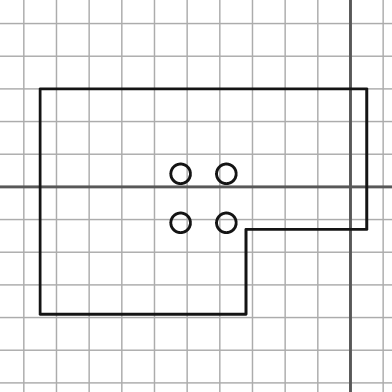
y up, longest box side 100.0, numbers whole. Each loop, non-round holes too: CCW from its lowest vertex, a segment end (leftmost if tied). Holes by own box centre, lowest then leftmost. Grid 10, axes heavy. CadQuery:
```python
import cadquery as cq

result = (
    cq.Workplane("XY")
    .moveTo(-95.0, -39.0)
    .lineTo(-32.0, -39.0)
    .lineTo(-32.0, -13.0)
    .lineTo(5.0, -13.0)
    .lineTo(5.0, 30.0)
    .lineTo(-95.0, 30.0)
    .close()
    .moveTo(-52.0, -11.0)
    .circle(3.0)
    .moveTo(-38.0, -11.0)
    .circle(3.0)
    .moveTo(-52.0, 4.0)
    .circle(3.0)
    .moveTo(-38.0, 4.0)
    .circle(3.0)
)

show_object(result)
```